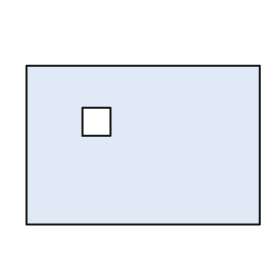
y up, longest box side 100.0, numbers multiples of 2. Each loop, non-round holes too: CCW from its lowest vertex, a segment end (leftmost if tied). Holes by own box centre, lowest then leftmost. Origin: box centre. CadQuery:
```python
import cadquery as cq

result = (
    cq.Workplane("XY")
    .moveTo(-50.0, -34.0)
    .lineTo(50.0, -34.0)
    .lineTo(50.0, 34.0)
    .lineTo(-50.0, 34.0)
    .close()
    .moveTo(-26.0, 4.0)
    .lineTo(-14.0, 4.0)
    .lineTo(-14.0, 16.0)
    .lineTo(-26.0, 16.0)
    .close()
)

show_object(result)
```